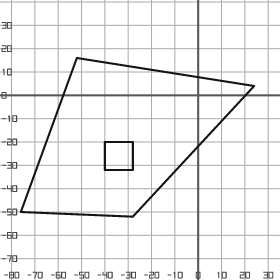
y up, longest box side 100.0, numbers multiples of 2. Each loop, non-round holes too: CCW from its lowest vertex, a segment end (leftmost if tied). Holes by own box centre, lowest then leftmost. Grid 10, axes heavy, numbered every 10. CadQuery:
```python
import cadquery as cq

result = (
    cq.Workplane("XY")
    .moveTo(-28.0, -52.0)
    .lineTo(24.0, 4.0)
    .lineTo(-52.0, 16.0)
    .lineTo(-76.0, -50.0)
    .close()
    .moveTo(-40.0, -32.0)
    .lineTo(-28.0, -32.0)
    .lineTo(-28.0, -20.0)
    .lineTo(-40.0, -20.0)
    .close()
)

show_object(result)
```